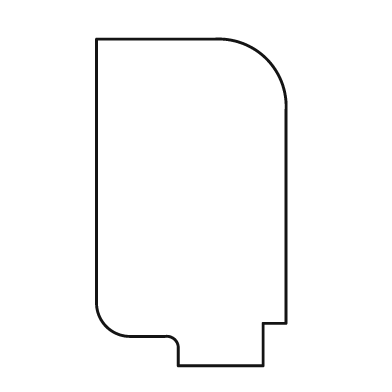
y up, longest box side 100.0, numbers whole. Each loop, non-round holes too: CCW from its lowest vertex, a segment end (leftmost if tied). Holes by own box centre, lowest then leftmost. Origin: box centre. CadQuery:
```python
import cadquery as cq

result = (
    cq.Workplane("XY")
    .moveTo(-4.0, -50.0)
    .lineTo(22.0, -50.0)
    .lineTo(22.0, -37.0)
    .lineTo(29.0, -37.0)
    .lineTo(29.0, 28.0)
    .threePointArc((23.0, 44.0), (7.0, 50.0))
    .lineTo(-29.0, 50.0)
    .lineTo(-29.0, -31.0)
    .threePointArc((-26.0, -38.0), (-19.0, -41.0))
    .lineTo(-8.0, -41.0)
    .threePointArc((-5.0, -42.0), (-4.0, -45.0))
    .close()
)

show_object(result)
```